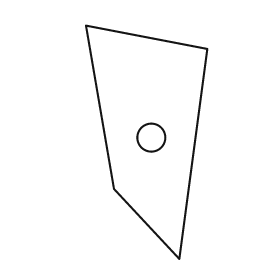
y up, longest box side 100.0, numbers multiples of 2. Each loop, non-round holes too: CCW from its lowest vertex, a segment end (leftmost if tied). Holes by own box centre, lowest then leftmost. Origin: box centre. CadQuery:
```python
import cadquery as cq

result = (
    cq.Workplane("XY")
    .moveTo(14.0, -50.0)
    .lineTo(26.0, 40.0)
    .lineTo(-26.0, 50.0)
    .lineTo(-14.0, -20.0)
    .close()
    .moveTo(2.0, 2.0)
    .circle(6.0)
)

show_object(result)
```